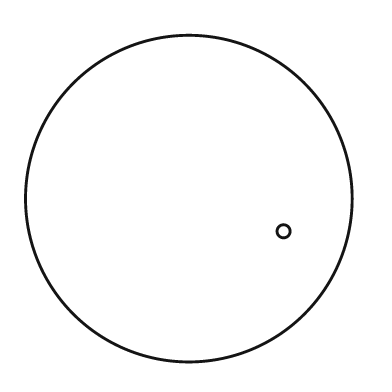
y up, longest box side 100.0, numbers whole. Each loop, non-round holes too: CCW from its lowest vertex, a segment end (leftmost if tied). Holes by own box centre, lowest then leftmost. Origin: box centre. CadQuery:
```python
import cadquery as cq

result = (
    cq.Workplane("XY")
    .moveTo(0.0, 0.0)
    .circle(50.0)
    .moveTo(29.0, -10.0)
    .circle(2.0)
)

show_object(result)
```